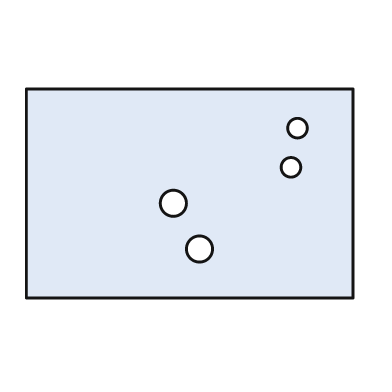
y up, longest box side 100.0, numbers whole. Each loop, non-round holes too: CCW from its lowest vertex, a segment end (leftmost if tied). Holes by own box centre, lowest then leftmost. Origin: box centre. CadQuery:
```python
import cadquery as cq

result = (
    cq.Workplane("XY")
    .moveTo(-50.0, -32.0)
    .lineTo(50.0, -32.0)
    .lineTo(50.0, 32.0)
    .lineTo(-50.0, 32.0)
    .close()
    .moveTo(3.0, -17.0)
    .circle(4.0)
    .moveTo(-5.0, -3.0)
    .circle(4.0)
    .moveTo(31.0, 8.0)
    .circle(3.0)
    .moveTo(33.0, 20.0)
    .circle(3.0)
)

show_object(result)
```